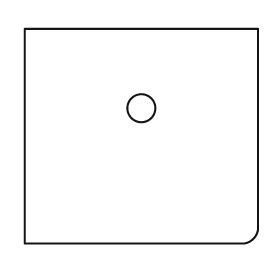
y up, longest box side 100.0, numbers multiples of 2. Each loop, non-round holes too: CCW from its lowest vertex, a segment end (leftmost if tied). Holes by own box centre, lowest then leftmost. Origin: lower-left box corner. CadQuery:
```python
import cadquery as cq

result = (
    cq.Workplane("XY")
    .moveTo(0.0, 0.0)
    .lineTo(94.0, 0.0)
    .threePointArc((98.0, 2.0), (100.0, 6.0))
    .lineTo(100.0, 92.0)
    .lineTo(0.0, 92.0)
    .close()
    .moveTo(50.0, 58.0)
    .circle(6.0)
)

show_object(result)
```